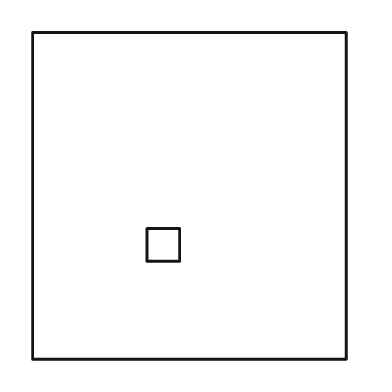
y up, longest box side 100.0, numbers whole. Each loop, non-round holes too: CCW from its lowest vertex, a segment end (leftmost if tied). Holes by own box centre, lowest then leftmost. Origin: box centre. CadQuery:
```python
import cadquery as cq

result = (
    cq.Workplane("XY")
    .moveTo(-48.0, -50.0)
    .lineTo(48.0, -50.0)
    .lineTo(48.0, 50.0)
    .lineTo(-48.0, 50.0)
    .close()
    .moveTo(-13.0, -20.0)
    .lineTo(-3.0, -20.0)
    .lineTo(-3.0, -10.0)
    .lineTo(-13.0, -10.0)
    .close()
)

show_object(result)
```